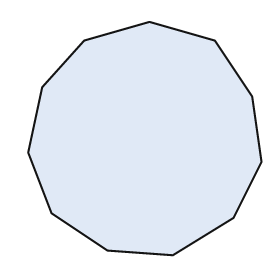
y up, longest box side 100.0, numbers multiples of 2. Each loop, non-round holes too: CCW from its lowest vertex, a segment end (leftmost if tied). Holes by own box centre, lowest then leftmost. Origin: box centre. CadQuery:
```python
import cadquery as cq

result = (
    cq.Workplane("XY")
    .moveTo(12.0, -50.0)
    .lineTo(38.0, -34.0)
    .lineTo(50.0, -10.0)
    .lineTo(46.0, 18.0)
    .lineTo(30.0, 42.0)
    .lineTo(2.0, 50.0)
    .lineTo(-26.0, 42.0)
    .lineTo(-44.0, 22.0)
    .lineTo(-50.0, -6.0)
    .lineTo(-40.0, -32.0)
    .lineTo(-16.0, -48.0)
    .close()
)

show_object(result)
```